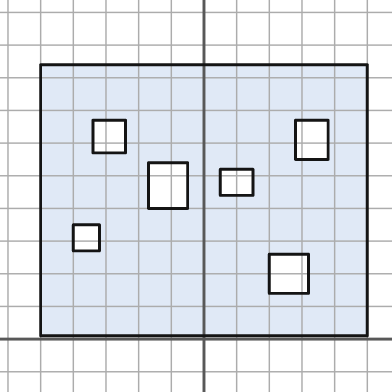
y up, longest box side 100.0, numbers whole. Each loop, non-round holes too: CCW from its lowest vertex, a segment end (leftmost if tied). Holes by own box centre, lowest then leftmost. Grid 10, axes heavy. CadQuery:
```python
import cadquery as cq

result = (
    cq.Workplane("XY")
    .moveTo(-50.0, 1.0)
    .lineTo(50.0, 1.0)
    .lineTo(50.0, 84.0)
    .lineTo(-50.0, 84.0)
    .close()
    .moveTo(20.0, 14.0)
    .lineTo(32.0, 14.0)
    .lineTo(32.0, 26.0)
    .lineTo(20.0, 26.0)
    .close()
    .moveTo(-40.0, 27.0)
    .lineTo(-32.0, 27.0)
    .lineTo(-32.0, 35.0)
    .lineTo(-40.0, 35.0)
    .close()
    .moveTo(-17.0, 40.0)
    .lineTo(-5.0, 40.0)
    .lineTo(-5.0, 54.0)
    .lineTo(-17.0, 54.0)
    .close()
    .moveTo(5.0, 44.0)
    .lineTo(15.0, 44.0)
    .lineTo(15.0, 52.0)
    .lineTo(5.0, 52.0)
    .close()
    .moveTo(28.0, 55.0)
    .lineTo(38.0, 55.0)
    .lineTo(38.0, 67.0)
    .lineTo(28.0, 67.0)
    .close()
    .moveTo(-34.0, 57.0)
    .lineTo(-24.0, 57.0)
    .lineTo(-24.0, 67.0)
    .lineTo(-34.0, 67.0)
    .close()
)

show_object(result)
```